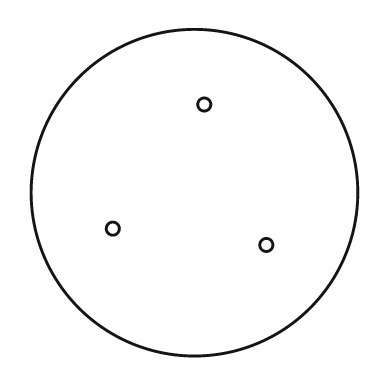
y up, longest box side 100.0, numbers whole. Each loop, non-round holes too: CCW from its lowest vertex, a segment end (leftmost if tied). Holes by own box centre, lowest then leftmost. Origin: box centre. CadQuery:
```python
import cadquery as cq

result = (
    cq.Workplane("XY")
    .moveTo(0.0, 0.0)
    .circle(50.0)
    .moveTo(22.0, -16.0)
    .circle(2.0)
    .moveTo(-25.0, -11.0)
    .circle(2.0)
    .moveTo(3.0, 27.0)
    .circle(2.0)
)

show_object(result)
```